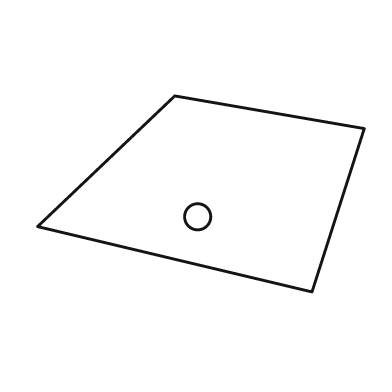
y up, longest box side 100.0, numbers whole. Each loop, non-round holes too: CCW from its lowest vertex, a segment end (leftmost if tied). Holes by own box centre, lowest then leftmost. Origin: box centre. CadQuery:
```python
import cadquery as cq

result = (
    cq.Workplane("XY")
    .moveTo(34.0, -30.0)
    .lineTo(50.0, 20.0)
    .lineTo(-8.0, 30.0)
    .lineTo(-50.0, -10.0)
    .close()
    .moveTo(-1.0, -7.0)
    .circle(4.0)
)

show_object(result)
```